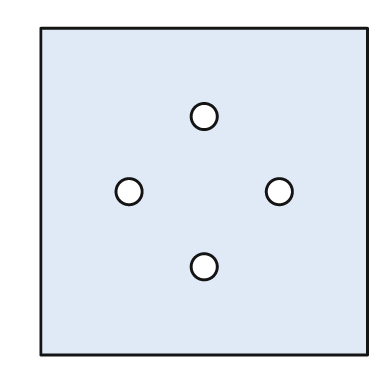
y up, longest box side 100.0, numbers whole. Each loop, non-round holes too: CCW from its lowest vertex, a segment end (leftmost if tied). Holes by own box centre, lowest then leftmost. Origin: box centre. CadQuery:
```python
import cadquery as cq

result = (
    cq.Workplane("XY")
    .moveTo(-50.0, -50.0)
    .lineTo(50.0, -50.0)
    .lineTo(50.0, 50.0)
    .lineTo(-50.0, 50.0)
    .close()
    .moveTo(0.0, -23.0)
    .circle(4.0)
    .moveTo(-23.0, 0.0)
    .circle(4.0)
    .moveTo(23.0, 0.0)
    .circle(4.0)
    .moveTo(0.0, 23.0)
    .circle(4.0)
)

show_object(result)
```